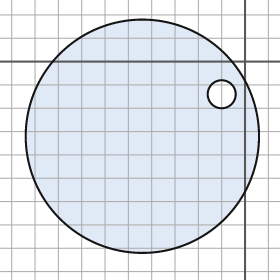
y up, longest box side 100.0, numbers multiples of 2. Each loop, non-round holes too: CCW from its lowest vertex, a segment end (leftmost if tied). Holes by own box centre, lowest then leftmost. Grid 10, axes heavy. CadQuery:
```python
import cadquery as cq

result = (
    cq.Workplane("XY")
    .moveTo(-44.0, -32.0)
    .circle(50.0)
    .moveTo(-10.0, -14.0)
    .circle(6.0)
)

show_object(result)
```